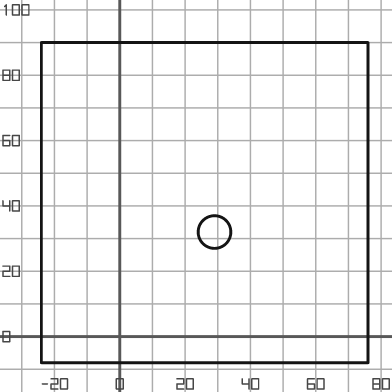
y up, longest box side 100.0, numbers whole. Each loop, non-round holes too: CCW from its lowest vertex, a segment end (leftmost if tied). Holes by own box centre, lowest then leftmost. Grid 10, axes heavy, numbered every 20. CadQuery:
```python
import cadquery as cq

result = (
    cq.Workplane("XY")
    .moveTo(-24.0, -8.0)
    .lineTo(76.0, -8.0)
    .lineTo(76.0, 90.0)
    .lineTo(-24.0, 90.0)
    .close()
    .moveTo(29.0, 32.0)
    .circle(5.0)
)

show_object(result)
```